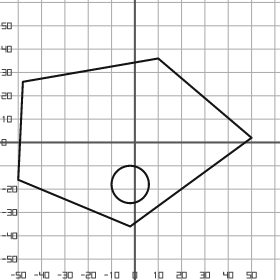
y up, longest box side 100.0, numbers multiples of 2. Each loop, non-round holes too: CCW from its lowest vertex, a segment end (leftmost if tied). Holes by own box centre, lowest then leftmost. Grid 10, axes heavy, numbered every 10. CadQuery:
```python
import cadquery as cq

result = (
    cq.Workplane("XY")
    .moveTo(-2.0, -36.0)
    .lineTo(50.0, 2.0)
    .lineTo(10.0, 36.0)
    .lineTo(-48.0, 26.0)
    .lineTo(-50.0, -16.0)
    .close()
    .moveTo(-2.0, -18.0)
    .circle(8.0)
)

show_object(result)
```